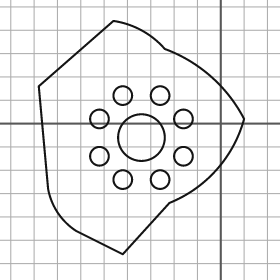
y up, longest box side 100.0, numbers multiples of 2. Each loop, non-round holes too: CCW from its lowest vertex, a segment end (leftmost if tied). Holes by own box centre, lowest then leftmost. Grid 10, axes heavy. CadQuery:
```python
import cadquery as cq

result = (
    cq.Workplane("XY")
    .moveTo(-42.0, -56.0)
    .lineTo(-22.0, -34.0)
    .threePointArc((-2.0, -20.0), (10.0, 2.0))
    .threePointArc((-4.0, 20.0), (-24.0, 32.0))
    .threePointArc((-34.0, 40.0), (-46.0, 44.0))
    .lineTo(-78.0, 16.0)
    .lineTo(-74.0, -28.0)
    .threePointArc((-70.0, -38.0), (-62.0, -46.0))
    .close()
    .moveTo(-42.0, -24.0)
    .circle(4.0)
    .moveTo(-26.0, -24.0)
    .circle(4.0)
    .moveTo(-52.0, -14.0)
    .circle(4.0)
    .moveTo(-16.0, -14.0)
    .circle(4.0)
    .moveTo(-34.0, -6.0)
    .circle(10.0)
    .moveTo(-52.0, 2.0)
    .circle(4.0)
    .moveTo(-16.0, 2.0)
    .circle(4.0)
    .moveTo(-42.0, 12.0)
    .circle(4.0)
    .moveTo(-26.0, 12.0)
    .circle(4.0)
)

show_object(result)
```